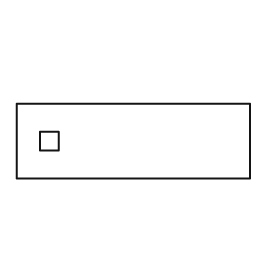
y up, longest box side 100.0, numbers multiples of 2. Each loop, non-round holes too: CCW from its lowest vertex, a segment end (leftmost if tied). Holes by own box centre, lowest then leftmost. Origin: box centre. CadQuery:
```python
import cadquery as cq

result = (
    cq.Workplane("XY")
    .moveTo(-50.0, -16.0)
    .lineTo(50.0, -16.0)
    .lineTo(50.0, 16.0)
    .lineTo(-50.0, 16.0)
    .close()
    .moveTo(-40.0, -4.0)
    .lineTo(-32.0, -4.0)
    .lineTo(-32.0, 4.0)
    .lineTo(-40.0, 4.0)
    .close()
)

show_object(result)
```